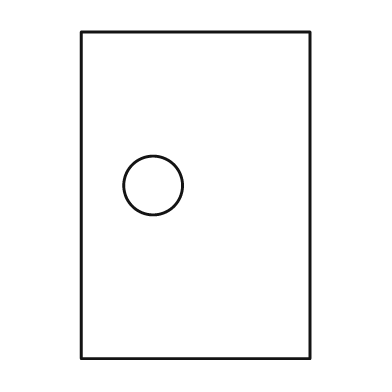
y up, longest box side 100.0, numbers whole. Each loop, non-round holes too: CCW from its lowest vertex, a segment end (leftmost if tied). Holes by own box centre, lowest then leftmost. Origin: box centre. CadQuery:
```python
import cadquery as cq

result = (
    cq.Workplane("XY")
    .moveTo(-35.0, -50.0)
    .lineTo(35.0, -50.0)
    .lineTo(35.0, 50.0)
    .lineTo(-35.0, 50.0)
    .close()
    .moveTo(-13.0, 3.0)
    .circle(9.0)
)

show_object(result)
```